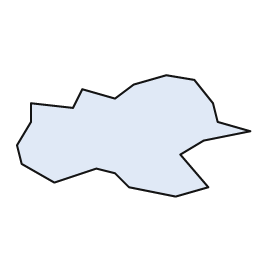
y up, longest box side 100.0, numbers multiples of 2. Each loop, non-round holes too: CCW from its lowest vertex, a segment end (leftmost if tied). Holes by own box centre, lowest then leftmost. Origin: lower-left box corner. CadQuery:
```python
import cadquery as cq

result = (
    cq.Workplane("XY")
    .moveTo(68.0, 0.0)
    .lineTo(82.0, 4.0)
    .lineTo(70.0, 18.0)
    .lineTo(80.0, 24.0)
    .lineTo(100.0, 28.0)
    .lineTo(86.0, 32.0)
    .lineTo(84.0, 40.0)
    .lineTo(76.0, 50.0)
    .lineTo(64.0, 52.0)
    .lineTo(50.0, 48.0)
    .lineTo(42.0, 42.0)
    .lineTo(28.0, 46.0)
    .lineTo(24.0, 38.0)
    .lineTo(6.0, 40.0)
    .lineTo(6.0, 32.0)
    .lineTo(0.0, 22.0)
    .lineTo(2.0, 14.0)
    .lineTo(16.0, 6.0)
    .lineTo(34.0, 12.0)
    .lineTo(42.0, 10.0)
    .lineTo(48.0, 4.0)
    .close()
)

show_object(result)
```